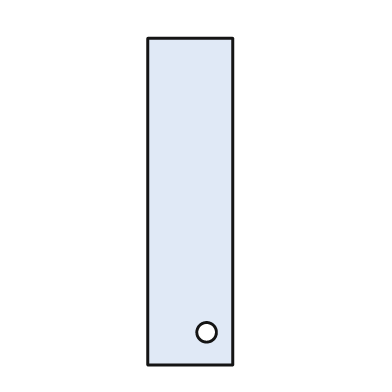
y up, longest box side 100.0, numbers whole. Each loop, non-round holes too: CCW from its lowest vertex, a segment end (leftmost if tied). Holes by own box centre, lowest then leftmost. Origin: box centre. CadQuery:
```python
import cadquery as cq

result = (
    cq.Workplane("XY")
    .moveTo(-13.0, -50.0)
    .lineTo(13.0, -50.0)
    .lineTo(13.0, 50.0)
    .lineTo(-13.0, 50.0)
    .close()
    .moveTo(5.0, -40.0)
    .circle(3.0)
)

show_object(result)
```